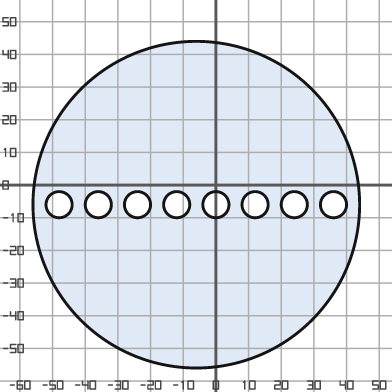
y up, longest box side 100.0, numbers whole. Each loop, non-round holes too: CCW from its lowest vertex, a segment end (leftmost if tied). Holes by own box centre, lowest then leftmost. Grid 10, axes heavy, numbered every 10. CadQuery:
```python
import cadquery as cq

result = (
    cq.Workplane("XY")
    .moveTo(-6.0, -6.0)
    .circle(50.0)
    .moveTo(-48.0, -6.0)
    .circle(4.0)
    .moveTo(-36.0, -6.0)
    .circle(4.0)
    .moveTo(-24.0, -6.0)
    .circle(4.0)
    .moveTo(-12.0, -6.0)
    .circle(4.0)
    .moveTo(0.0, -6.0)
    .circle(4.0)
    .moveTo(12.0, -6.0)
    .circle(4.0)
    .moveTo(24.0, -6.0)
    .circle(4.0)
    .moveTo(36.0, -6.0)
    .circle(4.0)
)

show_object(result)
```